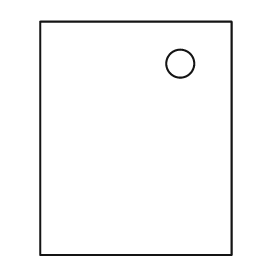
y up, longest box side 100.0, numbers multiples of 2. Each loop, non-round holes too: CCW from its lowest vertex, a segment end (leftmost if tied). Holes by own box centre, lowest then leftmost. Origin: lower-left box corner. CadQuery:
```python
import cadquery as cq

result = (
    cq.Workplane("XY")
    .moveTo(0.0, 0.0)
    .lineTo(82.0, 0.0)
    .lineTo(82.0, 100.0)
    .lineTo(0.0, 100.0)
    .close()
    .moveTo(60.0, 82.0)
    .circle(6.0)
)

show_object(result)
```